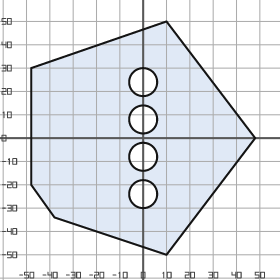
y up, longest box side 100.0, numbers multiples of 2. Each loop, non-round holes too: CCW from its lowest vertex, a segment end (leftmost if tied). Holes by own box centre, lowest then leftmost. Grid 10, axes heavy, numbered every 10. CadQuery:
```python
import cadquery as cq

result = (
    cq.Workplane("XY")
    .moveTo(10.0, -50.0)
    .lineTo(48.0, 0.0)
    .lineTo(10.0, 50.0)
    .lineTo(-48.0, 30.0)
    .lineTo(-48.0, -20.0)
    .lineTo(-38.0, -34.0)
    .close()
    .moveTo(0.0, -24.0)
    .circle(6.0)
    .moveTo(0.0, -8.0)
    .circle(6.0)
    .moveTo(0.0, 8.0)
    .circle(6.0)
    .moveTo(0.0, 24.0)
    .circle(6.0)
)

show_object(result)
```